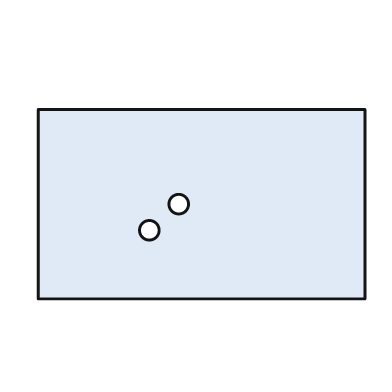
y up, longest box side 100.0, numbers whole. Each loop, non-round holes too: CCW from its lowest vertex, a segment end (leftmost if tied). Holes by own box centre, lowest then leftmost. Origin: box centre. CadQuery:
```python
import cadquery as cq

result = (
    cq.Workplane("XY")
    .moveTo(-50.0, -29.0)
    .lineTo(50.0, -29.0)
    .lineTo(50.0, 29.0)
    .lineTo(-50.0, 29.0)
    .close()
    .moveTo(-16.0, -8.0)
    .circle(3.0)
    .moveTo(-7.0, 0.0)
    .circle(3.0)
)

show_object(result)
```